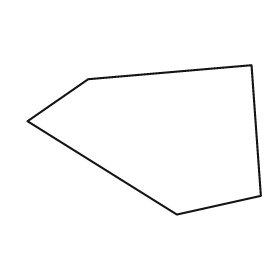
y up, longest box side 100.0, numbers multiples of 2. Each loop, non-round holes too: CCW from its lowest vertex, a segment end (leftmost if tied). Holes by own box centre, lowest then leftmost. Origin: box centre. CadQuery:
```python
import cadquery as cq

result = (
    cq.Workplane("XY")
    .moveTo(14.0, -32.0)
    .lineTo(50.0, -24.0)
    .lineTo(46.0, 32.0)
    .lineTo(-24.0, 26.0)
    .lineTo(-50.0, 8.0)
    .close()
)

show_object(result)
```